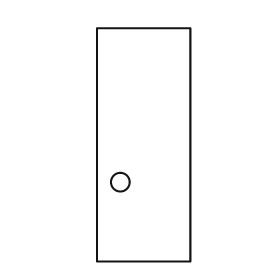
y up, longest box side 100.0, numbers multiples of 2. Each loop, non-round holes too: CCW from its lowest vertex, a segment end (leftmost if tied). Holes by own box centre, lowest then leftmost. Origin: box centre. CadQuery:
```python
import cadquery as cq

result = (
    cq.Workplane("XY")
    .moveTo(-20.0, -50.0)
    .lineTo(20.0, -50.0)
    .lineTo(20.0, 50.0)
    .lineTo(-20.0, 50.0)
    .close()
    .moveTo(-10.0, -16.0)
    .circle(4.0)
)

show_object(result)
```